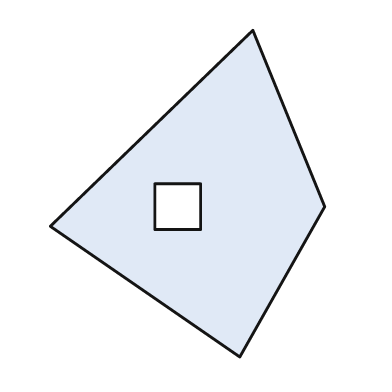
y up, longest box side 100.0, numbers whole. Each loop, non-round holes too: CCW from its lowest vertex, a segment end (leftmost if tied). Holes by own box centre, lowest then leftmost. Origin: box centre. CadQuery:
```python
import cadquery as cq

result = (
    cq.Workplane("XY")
    .moveTo(16.0, -50.0)
    .lineTo(42.0, -4.0)
    .lineTo(20.0, 50.0)
    .lineTo(-42.0, -10.0)
    .close()
    .moveTo(-10.0, -11.0)
    .lineTo(4.0, -11.0)
    .lineTo(4.0, 3.0)
    .lineTo(-10.0, 3.0)
    .close()
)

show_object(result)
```